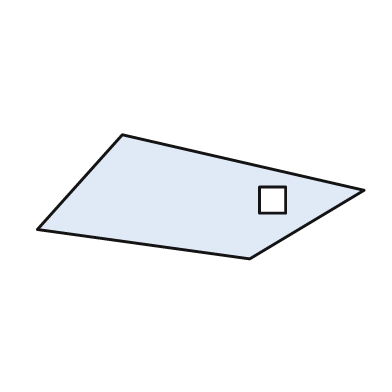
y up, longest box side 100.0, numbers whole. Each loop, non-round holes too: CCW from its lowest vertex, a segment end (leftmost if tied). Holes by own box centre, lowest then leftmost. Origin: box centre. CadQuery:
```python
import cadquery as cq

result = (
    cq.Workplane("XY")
    .moveTo(15.0, -19.0)
    .lineTo(50.0, 2.0)
    .lineTo(-24.0, 19.0)
    .lineTo(-50.0, -10.0)
    .close()
    .moveTo(18.0, -5.0)
    .lineTo(26.0, -5.0)
    .lineTo(26.0, 3.0)
    .lineTo(18.0, 3.0)
    .close()
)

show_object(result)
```